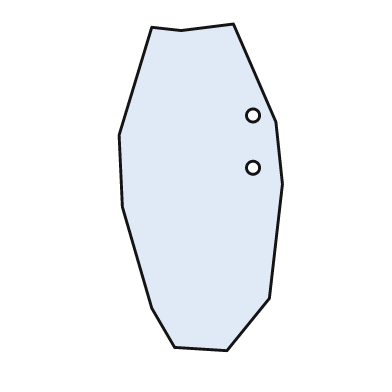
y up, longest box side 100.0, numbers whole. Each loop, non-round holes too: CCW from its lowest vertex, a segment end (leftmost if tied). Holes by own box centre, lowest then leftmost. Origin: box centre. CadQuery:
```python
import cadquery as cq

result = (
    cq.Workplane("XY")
    .moveTo(8.0, -50.0)
    .lineTo(21.0, -34.0)
    .lineTo(25.0, 1.0)
    .lineTo(23.0, 20.0)
    .lineTo(10.0, 50.0)
    .lineTo(-6.0, 48.0)
    .lineTo(-15.0, 49.0)
    .lineTo(-25.0, 16.0)
    .lineTo(-24.0, -6.0)
    .lineTo(-15.0, -37.0)
    .lineTo(-8.0, -49.0)
    .close()
    .moveTo(16.0, 6.0)
    .circle(2.0)
    .moveTo(16.0, 22.0)
    .circle(2.0)
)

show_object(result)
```